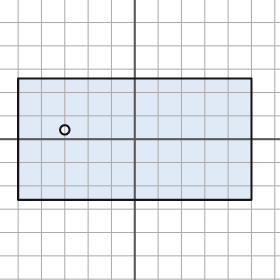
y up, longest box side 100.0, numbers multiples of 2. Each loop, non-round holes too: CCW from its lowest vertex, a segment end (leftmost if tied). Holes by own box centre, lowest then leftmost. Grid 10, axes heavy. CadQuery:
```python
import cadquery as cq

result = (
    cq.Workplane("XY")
    .moveTo(-50.0, -26.0)
    .lineTo(50.0, -26.0)
    .lineTo(50.0, 26.0)
    .lineTo(-50.0, 26.0)
    .close()
    .moveTo(-30.0, 4.0)
    .circle(2.0)
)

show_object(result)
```